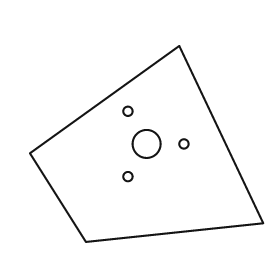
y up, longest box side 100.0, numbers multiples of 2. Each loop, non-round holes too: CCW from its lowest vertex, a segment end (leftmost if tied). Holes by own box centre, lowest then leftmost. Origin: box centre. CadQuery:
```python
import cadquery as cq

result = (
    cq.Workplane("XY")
    .moveTo(-26.0, -42.0)
    .lineTo(50.0, -34.0)
    .lineTo(14.0, 42.0)
    .lineTo(-50.0, -4.0)
    .close()
    .moveTo(-8.0, -14.0)
    .circle(2.0)
    .moveTo(0.0, 0.0)
    .circle(6.0)
    .moveTo(16.0, 0.0)
    .circle(2.0)
    .moveTo(-8.0, 14.0)
    .circle(2.0)
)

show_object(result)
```